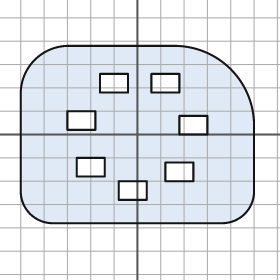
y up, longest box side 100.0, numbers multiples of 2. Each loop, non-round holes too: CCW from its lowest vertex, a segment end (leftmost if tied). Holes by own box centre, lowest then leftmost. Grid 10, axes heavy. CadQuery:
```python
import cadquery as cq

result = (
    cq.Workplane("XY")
    .moveTo(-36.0, -38.0)
    .lineTo(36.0, -38.0)
    .threePointArc((46.0, -34.0), (50.0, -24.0))
    .lineTo(50.0, 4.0)
    .threePointArc((40.0, 28.0), (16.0, 38.0))
    .lineTo(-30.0, 38.0)
    .threePointArc((-44.0, 32.0), (-50.0, 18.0))
    .lineTo(-50.0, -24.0)
    .threePointArc((-46.0, -34.0), (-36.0, -38.0))
    .close()
    .moveTo(-8.0, -28.0)
    .lineTo(4.0, -28.0)
    .lineTo(4.0, -20.0)
    .lineTo(-8.0, -20.0)
    .close()
    .moveTo(12.0, -20.0)
    .lineTo(24.0, -20.0)
    .lineTo(24.0, -12.0)
    .lineTo(12.0, -12.0)
    .close()
    .moveTo(-26.0, -18.0)
    .lineTo(-14.0, -18.0)
    .lineTo(-14.0, -10.0)
    .lineTo(-26.0, -10.0)
    .close()
    .moveTo(18.0, 0.0)
    .lineTo(30.0, 0.0)
    .lineTo(30.0, 8.0)
    .lineTo(18.0, 8.0)
    .close()
    .moveTo(-30.0, 2.0)
    .lineTo(-18.0, 2.0)
    .lineTo(-18.0, 10.0)
    .lineTo(-30.0, 10.0)
    .close()
    .moveTo(-16.0, 18.0)
    .lineTo(-4.0, 18.0)
    .lineTo(-4.0, 26.0)
    .lineTo(-16.0, 26.0)
    .close()
    .moveTo(6.0, 18.0)
    .lineTo(18.0, 18.0)
    .lineTo(18.0, 26.0)
    .lineTo(6.0, 26.0)
    .close()
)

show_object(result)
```